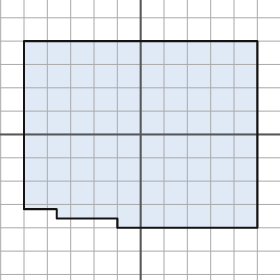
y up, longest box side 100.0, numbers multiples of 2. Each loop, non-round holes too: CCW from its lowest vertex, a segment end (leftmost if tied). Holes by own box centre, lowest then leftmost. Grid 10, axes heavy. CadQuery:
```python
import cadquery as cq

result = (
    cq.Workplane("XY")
    .moveTo(-10.0, -40.0)
    .lineTo(50.0, -40.0)
    .lineTo(50.0, 40.0)
    .lineTo(-50.0, 40.0)
    .lineTo(-50.0, -32.0)
    .lineTo(-36.0, -32.0)
    .lineTo(-36.0, -36.0)
    .lineTo(-10.0, -36.0)
    .close()
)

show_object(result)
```